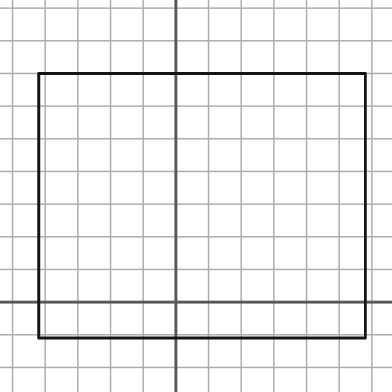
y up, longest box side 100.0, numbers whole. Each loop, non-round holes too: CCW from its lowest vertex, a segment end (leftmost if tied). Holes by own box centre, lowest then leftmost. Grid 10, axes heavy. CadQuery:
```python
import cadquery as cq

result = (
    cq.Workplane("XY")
    .moveTo(-42.0, -11.0)
    .lineTo(58.0, -11.0)
    .lineTo(58.0, 70.0)
    .lineTo(-42.0, 70.0)
    .close()
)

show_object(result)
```